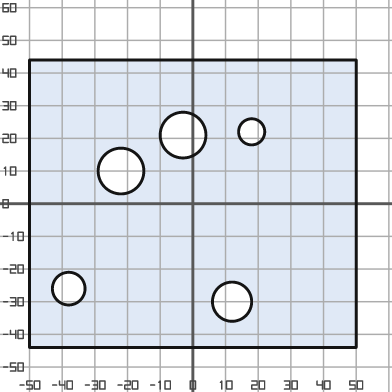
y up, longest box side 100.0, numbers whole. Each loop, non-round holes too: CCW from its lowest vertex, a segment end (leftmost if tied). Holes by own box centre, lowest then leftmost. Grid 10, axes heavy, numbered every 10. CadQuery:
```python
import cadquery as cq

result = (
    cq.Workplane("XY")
    .moveTo(-50.0, -44.0)
    .lineTo(50.0, -44.0)
    .lineTo(50.0, 44.0)
    .lineTo(-50.0, 44.0)
    .close()
    .moveTo(12.0, -30.0)
    .circle(6.0)
    .moveTo(-38.0, -26.0)
    .circle(5.0)
    .moveTo(-22.0, 10.0)
    .circle(7.0)
    .moveTo(-3.0, 21.0)
    .circle(7.0)
    .moveTo(18.0, 22.0)
    .circle(4.0)
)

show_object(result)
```